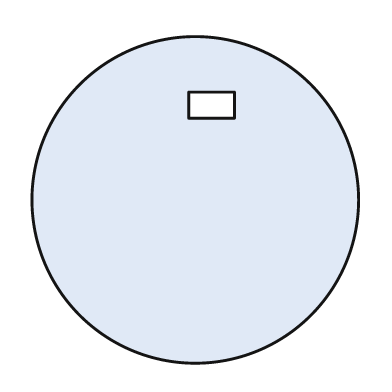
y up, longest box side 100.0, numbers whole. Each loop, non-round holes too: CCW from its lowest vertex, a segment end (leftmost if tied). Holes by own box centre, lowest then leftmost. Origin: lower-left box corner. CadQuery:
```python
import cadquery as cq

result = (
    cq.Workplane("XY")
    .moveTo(50.0, 50.0)
    .circle(50.0)
    .moveTo(48.0, 75.0)
    .lineTo(62.0, 75.0)
    .lineTo(62.0, 83.0)
    .lineTo(48.0, 83.0)
    .close()
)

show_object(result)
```